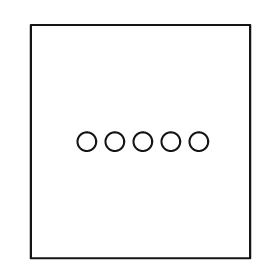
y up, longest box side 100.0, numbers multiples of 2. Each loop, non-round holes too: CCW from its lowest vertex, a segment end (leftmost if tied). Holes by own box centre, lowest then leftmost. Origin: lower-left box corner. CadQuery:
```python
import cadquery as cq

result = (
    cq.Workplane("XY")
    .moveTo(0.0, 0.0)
    .lineTo(94.0, 0.0)
    .lineTo(94.0, 100.0)
    .lineTo(0.0, 100.0)
    .close()
    .moveTo(24.0, 50.0)
    .circle(4.0)
    .moveTo(36.0, 50.0)
    .circle(4.0)
    .moveTo(48.0, 50.0)
    .circle(4.0)
    .moveTo(60.0, 50.0)
    .circle(4.0)
    .moveTo(72.0, 50.0)
    .circle(4.0)
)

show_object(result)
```